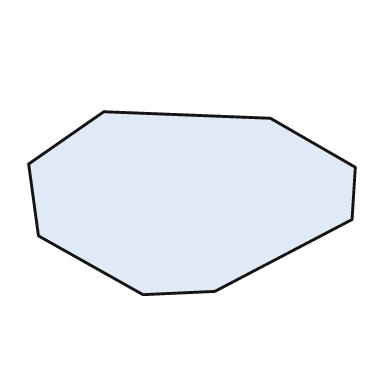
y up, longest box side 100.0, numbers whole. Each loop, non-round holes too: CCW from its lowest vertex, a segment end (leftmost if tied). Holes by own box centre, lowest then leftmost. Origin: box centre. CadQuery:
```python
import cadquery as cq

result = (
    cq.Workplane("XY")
    .moveTo(-15.0, -28.0)
    .lineTo(7.0, -27.0)
    .lineTo(49.0, -5.0)
    .lineTo(50.0, 11.0)
    .lineTo(24.0, 26.0)
    .lineTo(-27.0, 28.0)
    .lineTo(-50.0, 12.0)
    .lineTo(-47.0, -10.0)
    .close()
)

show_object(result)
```